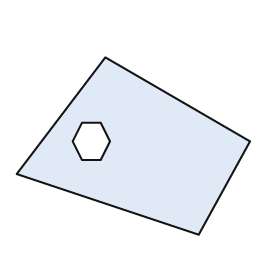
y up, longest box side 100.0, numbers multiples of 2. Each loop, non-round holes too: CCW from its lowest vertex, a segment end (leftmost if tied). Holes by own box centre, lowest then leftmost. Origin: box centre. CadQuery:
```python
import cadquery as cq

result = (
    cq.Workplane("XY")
    .moveTo(28.0, -38.0)
    .lineTo(50.0, 2.0)
    .lineTo(-12.0, 38.0)
    .lineTo(-50.0, -12.0)
    .close()
    .moveTo(-22.0, -6.0)
    .lineTo(-14.0, -6.0)
    .lineTo(-10.0, 2.0)
    .lineTo(-14.0, 10.0)
    .lineTo(-22.0, 10.0)
    .lineTo(-26.0, 2.0)
    .close()
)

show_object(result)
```